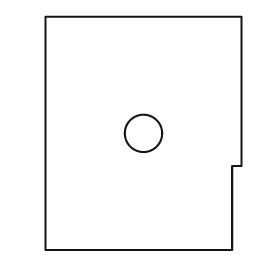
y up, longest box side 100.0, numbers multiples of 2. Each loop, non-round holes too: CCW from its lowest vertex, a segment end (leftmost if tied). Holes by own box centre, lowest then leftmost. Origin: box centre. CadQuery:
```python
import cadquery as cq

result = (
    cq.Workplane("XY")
    .moveTo(-42.0, -50.0)
    .lineTo(38.0, -50.0)
    .lineTo(38.0, -14.0)
    .lineTo(42.0, -14.0)
    .lineTo(42.0, 50.0)
    .lineTo(-42.0, 50.0)
    .close()
    .moveTo(0.0, 0.0)
    .circle(8.0)
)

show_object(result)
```